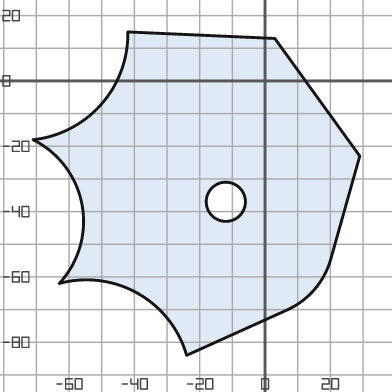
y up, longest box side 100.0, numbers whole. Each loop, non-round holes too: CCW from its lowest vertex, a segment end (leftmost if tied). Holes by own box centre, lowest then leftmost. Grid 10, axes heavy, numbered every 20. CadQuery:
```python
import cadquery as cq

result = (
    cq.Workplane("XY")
    .moveTo(-24.0, -84.0)
    .lineTo(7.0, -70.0)
    .threePointArc((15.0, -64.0), (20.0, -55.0))
    .lineTo(29.0, -23.0)
    .lineTo(3.0, 13.0)
    .lineTo(-42.0, 15.0)
    .threePointArc((-50.0, -7.0), (-71.0, -18.0))
    .threePointArc((-56.0, -38.0), (-63.0, -62.0))
    .threePointArc((-39.0, -65.0), (-24.0, -84.0))
    .close()
    .moveTo(-12.0, -37.0)
    .circle(6.0)
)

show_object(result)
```